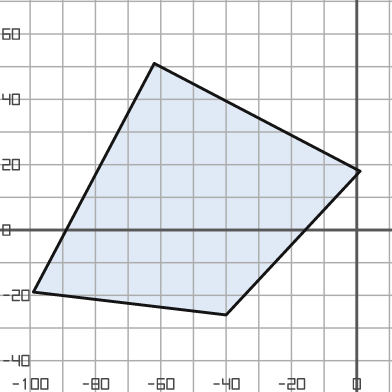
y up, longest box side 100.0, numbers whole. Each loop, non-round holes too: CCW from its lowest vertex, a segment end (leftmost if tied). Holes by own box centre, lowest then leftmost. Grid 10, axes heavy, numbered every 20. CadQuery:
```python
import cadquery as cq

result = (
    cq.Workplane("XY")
    .moveTo(-40.0, -26.0)
    .lineTo(1.0, 18.0)
    .lineTo(-62.0, 51.0)
    .lineTo(-99.0, -19.0)
    .close()
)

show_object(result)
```